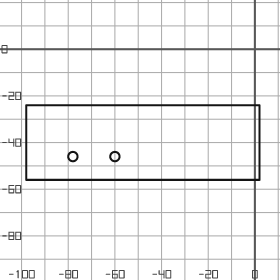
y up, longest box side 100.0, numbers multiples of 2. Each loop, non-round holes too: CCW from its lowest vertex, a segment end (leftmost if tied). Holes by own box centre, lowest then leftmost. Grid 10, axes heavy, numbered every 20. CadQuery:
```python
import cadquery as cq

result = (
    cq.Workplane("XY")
    .moveTo(-98.0, -56.0)
    .lineTo(2.0, -56.0)
    .lineTo(2.0, -24.0)
    .lineTo(-98.0, -24.0)
    .close()
    .moveTo(-78.0, -46.0)
    .circle(2.0)
    .moveTo(-60.0, -46.0)
    .circle(2.0)
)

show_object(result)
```